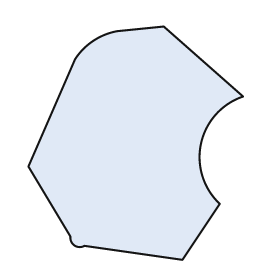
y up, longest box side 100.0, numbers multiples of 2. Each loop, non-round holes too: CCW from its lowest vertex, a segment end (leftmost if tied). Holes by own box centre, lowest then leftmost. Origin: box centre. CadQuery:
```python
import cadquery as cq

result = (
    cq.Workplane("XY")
    .moveTo(20.0, -50.0)
    .lineTo(36.0, -26.0)
    .threePointArc((28.0, 0.0), (46.0, 20.0))
    .lineTo(12.0, 50.0)
    .lineTo(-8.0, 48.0)
    .threePointArc((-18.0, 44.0), (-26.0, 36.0))
    .lineTo(-46.0, -10.0)
    .lineTo(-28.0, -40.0)
    .threePointArc((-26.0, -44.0), (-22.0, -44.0))
    .close()
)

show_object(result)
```